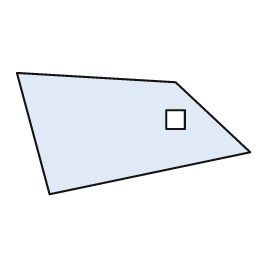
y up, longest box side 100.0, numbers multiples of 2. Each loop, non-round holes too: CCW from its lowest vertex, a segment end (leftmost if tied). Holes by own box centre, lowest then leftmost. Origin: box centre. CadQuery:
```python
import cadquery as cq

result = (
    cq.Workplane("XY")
    .moveTo(-36.0, -26.0)
    .lineTo(50.0, -8.0)
    .lineTo(18.0, 22.0)
    .lineTo(-50.0, 26.0)
    .close()
    .moveTo(14.0, 2.0)
    .lineTo(22.0, 2.0)
    .lineTo(22.0, 10.0)
    .lineTo(14.0, 10.0)
    .close()
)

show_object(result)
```